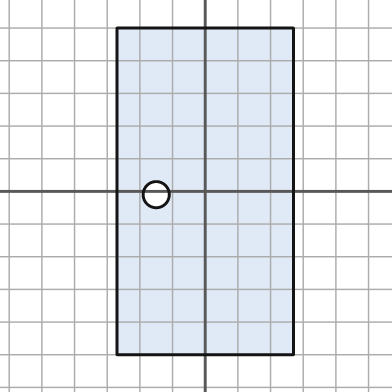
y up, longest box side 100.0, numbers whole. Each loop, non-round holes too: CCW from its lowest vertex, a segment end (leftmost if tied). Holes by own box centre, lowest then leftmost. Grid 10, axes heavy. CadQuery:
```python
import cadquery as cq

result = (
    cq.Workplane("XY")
    .moveTo(-27.0, -50.0)
    .lineTo(27.0, -50.0)
    .lineTo(27.0, 50.0)
    .lineTo(-27.0, 50.0)
    .close()
    .moveTo(-15.0, -1.0)
    .circle(4.0)
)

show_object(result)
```